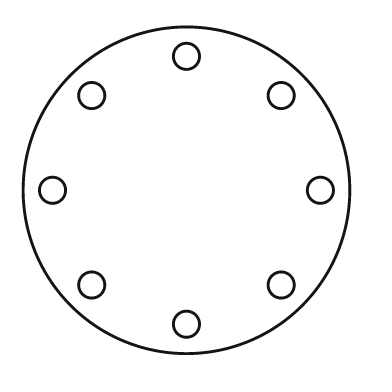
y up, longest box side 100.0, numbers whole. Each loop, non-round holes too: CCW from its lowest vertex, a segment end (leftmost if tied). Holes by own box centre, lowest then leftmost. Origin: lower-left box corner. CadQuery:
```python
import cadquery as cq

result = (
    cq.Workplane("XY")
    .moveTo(50.0, 50.0)
    .circle(50.0)
    .moveTo(50.0, 9.0)
    .circle(4.0)
    .moveTo(21.0, 21.0)
    .circle(4.0)
    .moveTo(79.0, 21.0)
    .circle(4.0)
    .moveTo(9.0, 50.0)
    .circle(4.0)
    .moveTo(91.0, 50.0)
    .circle(4.0)
    .moveTo(21.0, 79.0)
    .circle(4.0)
    .moveTo(79.0, 79.0)
    .circle(4.0)
    .moveTo(50.0, 91.0)
    .circle(4.0)
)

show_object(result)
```